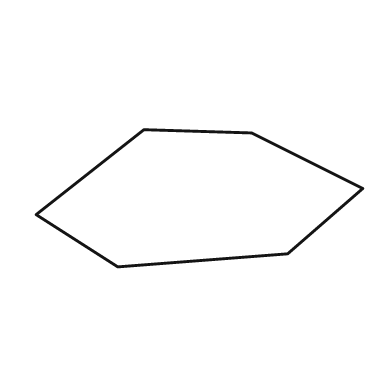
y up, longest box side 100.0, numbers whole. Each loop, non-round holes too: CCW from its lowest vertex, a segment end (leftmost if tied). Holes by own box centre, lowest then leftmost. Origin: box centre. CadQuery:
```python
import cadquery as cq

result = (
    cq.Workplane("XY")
    .moveTo(-25.0, -21.0)
    .lineTo(27.0, -17.0)
    .lineTo(50.0, 3.0)
    .lineTo(16.0, 20.0)
    .lineTo(-17.0, 21.0)
    .lineTo(-50.0, -5.0)
    .close()
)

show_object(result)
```